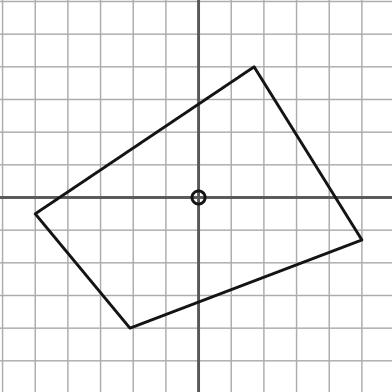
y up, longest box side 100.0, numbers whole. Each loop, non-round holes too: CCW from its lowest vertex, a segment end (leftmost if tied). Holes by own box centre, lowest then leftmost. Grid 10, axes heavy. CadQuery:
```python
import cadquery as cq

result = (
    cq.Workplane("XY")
    .moveTo(-21.0, -40.0)
    .lineTo(50.0, -13.0)
    .lineTo(17.0, 40.0)
    .lineTo(-50.0, -5.0)
    .close()
    .moveTo(0.0, 0.0)
    .circle(2.0)
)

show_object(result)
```